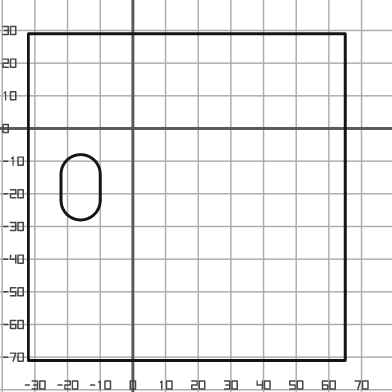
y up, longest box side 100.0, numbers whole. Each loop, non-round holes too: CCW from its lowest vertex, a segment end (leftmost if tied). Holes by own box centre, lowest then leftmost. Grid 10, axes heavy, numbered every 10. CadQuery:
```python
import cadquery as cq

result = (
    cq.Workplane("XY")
    .moveTo(-32.0, -71.0)
    .lineTo(65.0, -71.0)
    .lineTo(65.0, 29.0)
    .lineTo(-32.0, 29.0)
    .close()
    .moveTo(-22.0, -22.0)
    .threePointArc((-16.0, -28.0), (-10.0, -22.0))
    .lineTo(-10.0, -14.0)
    .threePointArc((-16.0, -8.0), (-22.0, -14.0))
    .close()
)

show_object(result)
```